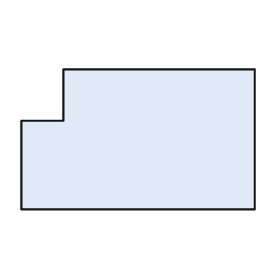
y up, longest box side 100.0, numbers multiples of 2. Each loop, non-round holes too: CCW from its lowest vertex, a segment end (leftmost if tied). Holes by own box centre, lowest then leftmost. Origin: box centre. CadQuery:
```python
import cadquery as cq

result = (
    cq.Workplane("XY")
    .moveTo(-50.0, -30.0)
    .lineTo(50.0, -30.0)
    .lineTo(50.0, 30.0)
    .lineTo(-32.0, 30.0)
    .lineTo(-32.0, 8.0)
    .lineTo(-50.0, 8.0)
    .close()
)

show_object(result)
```